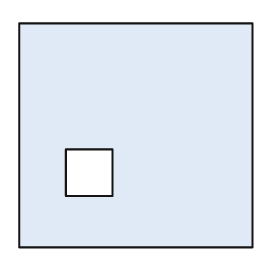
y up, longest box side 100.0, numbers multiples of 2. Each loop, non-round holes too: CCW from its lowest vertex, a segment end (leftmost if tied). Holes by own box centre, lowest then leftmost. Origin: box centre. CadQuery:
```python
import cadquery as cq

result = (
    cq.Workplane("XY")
    .moveTo(-50.0, -48.0)
    .lineTo(50.0, -48.0)
    .lineTo(50.0, 48.0)
    .lineTo(-50.0, 48.0)
    .close()
    .moveTo(-30.0, -26.0)
    .lineTo(-10.0, -26.0)
    .lineTo(-10.0, -6.0)
    .lineTo(-30.0, -6.0)
    .close()
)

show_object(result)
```